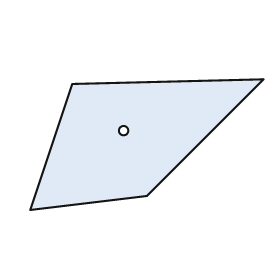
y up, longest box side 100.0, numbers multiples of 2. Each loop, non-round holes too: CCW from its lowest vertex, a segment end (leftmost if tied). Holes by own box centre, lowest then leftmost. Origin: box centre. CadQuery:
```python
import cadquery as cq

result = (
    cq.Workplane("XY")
    .moveTo(-50.0, -28.0)
    .lineTo(0.0, -22.0)
    .lineTo(50.0, 28.0)
    .lineTo(-32.0, 26.0)
    .close()
    .moveTo(-10.0, 6.0)
    .circle(2.0)
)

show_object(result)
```